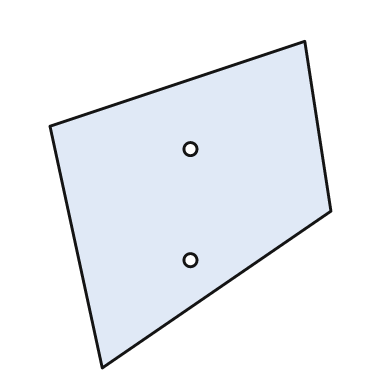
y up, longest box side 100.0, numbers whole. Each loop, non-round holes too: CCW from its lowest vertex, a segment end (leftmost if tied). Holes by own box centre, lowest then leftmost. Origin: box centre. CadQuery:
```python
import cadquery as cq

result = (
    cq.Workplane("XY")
    .moveTo(-27.0, -50.0)
    .lineTo(43.0, -2.0)
    .lineTo(35.0, 50.0)
    .lineTo(-43.0, 24.0)
    .close()
    .moveTo(0.0, -17.0)
    .circle(2.0)
    .moveTo(0.0, 17.0)
    .circle(2.0)
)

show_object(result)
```